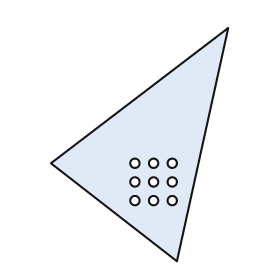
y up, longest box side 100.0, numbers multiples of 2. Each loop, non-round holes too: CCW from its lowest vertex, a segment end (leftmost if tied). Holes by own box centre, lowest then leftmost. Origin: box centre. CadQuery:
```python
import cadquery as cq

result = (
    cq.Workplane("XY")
    .moveTo(16.0, -50.0)
    .lineTo(38.0, 50.0)
    .lineTo(-38.0, -8.0)
    .close()
    .moveTo(-2.0, -24.0)
    .circle(2.0)
    .moveTo(6.0, -24.0)
    .circle(2.0)
    .moveTo(14.0, -24.0)
    .circle(2.0)
    .moveTo(-2.0, -16.0)
    .circle(2.0)
    .moveTo(6.0, -16.0)
    .circle(2.0)
    .moveTo(14.0, -16.0)
    .circle(2.0)
    .moveTo(-2.0, -8.0)
    .circle(2.0)
    .moveTo(6.0, -8.0)
    .circle(2.0)
    .moveTo(14.0, -8.0)
    .circle(2.0)
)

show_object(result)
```